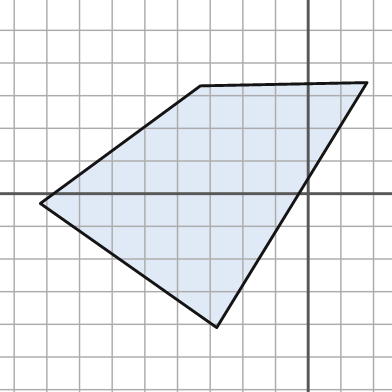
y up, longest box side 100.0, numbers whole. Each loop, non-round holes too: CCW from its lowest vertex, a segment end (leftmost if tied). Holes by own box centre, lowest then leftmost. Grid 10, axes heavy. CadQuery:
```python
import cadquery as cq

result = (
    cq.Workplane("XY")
    .moveTo(-28.0, -41.0)
    .lineTo(18.0, 34.0)
    .lineTo(-33.0, 33.0)
    .lineTo(-82.0, -3.0)
    .close()
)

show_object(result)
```